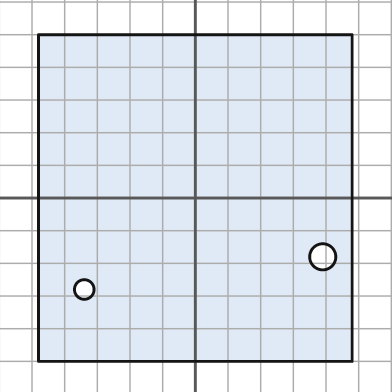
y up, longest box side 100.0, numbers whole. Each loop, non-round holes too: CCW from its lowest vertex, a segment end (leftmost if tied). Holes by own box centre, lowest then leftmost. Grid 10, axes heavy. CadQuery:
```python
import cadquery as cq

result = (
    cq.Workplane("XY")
    .moveTo(-48.0, -50.0)
    .lineTo(48.0, -50.0)
    .lineTo(48.0, 50.0)
    .lineTo(-48.0, 50.0)
    .close()
    .moveTo(-34.0, -28.0)
    .circle(3.0)
    .moveTo(39.0, -18.0)
    .circle(4.0)
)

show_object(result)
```